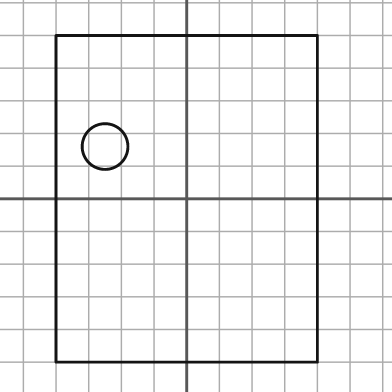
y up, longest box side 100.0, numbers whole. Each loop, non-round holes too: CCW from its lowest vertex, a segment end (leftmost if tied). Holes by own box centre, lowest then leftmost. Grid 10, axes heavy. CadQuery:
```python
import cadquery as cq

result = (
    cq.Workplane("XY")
    .moveTo(-40.0, -50.0)
    .lineTo(40.0, -50.0)
    .lineTo(40.0, 50.0)
    .lineTo(-40.0, 50.0)
    .close()
    .moveTo(-25.0, 16.0)
    .circle(7.0)
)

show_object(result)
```